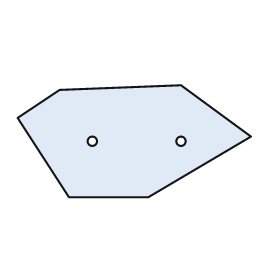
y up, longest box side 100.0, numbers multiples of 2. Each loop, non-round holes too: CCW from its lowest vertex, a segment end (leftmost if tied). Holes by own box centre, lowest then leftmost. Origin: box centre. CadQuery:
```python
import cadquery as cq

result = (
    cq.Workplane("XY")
    .moveTo(-28.0, -24.0)
    .lineTo(6.0, -24.0)
    .lineTo(50.0, 2.0)
    .lineTo(20.0, 24.0)
    .lineTo(-32.0, 22.0)
    .lineTo(-50.0, 10.0)
    .close()
    .moveTo(-18.0, 0.0)
    .circle(2.0)
    .moveTo(20.0, 0.0)
    .circle(2.0)
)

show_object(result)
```